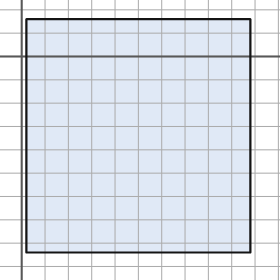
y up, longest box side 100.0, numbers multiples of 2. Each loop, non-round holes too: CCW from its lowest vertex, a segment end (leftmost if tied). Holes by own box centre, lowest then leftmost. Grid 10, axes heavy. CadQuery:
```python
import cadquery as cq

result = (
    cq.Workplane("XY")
    .moveTo(2.0, -84.0)
    .lineTo(98.0, -84.0)
    .lineTo(98.0, 16.0)
    .lineTo(2.0, 16.0)
    .close()
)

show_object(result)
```